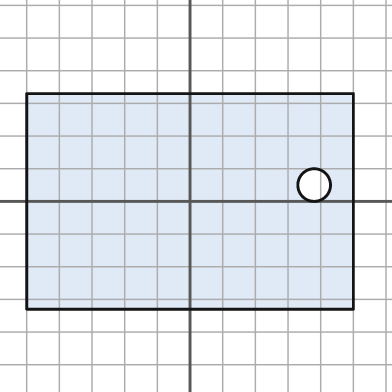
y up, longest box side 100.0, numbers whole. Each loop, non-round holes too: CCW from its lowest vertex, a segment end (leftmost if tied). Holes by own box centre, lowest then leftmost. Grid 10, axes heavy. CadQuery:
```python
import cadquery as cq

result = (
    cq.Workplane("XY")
    .moveTo(-50.0, -33.0)
    .lineTo(50.0, -33.0)
    .lineTo(50.0, 33.0)
    .lineTo(-50.0, 33.0)
    .close()
    .moveTo(38.0, 5.0)
    .circle(5.0)
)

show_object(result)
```